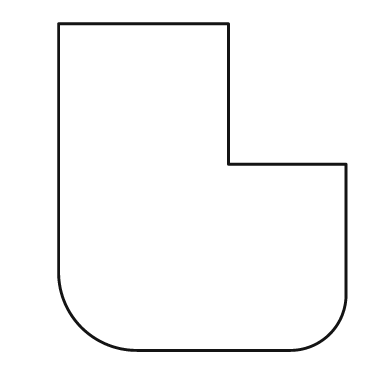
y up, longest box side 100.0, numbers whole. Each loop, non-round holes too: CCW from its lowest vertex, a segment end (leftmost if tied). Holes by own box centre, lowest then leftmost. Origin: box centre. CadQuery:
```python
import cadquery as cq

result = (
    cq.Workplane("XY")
    .moveTo(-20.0, -50.0)
    .lineTo(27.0, -50.0)
    .threePointArc((39.0, -45.0), (44.0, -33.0))
    .lineTo(44.0, 7.0)
    .lineTo(8.0, 7.0)
    .lineTo(8.0, 50.0)
    .lineTo(-44.0, 50.0)
    .lineTo(-44.0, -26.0)
    .threePointArc((-37.0, -43.0), (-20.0, -50.0))
    .close()
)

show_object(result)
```